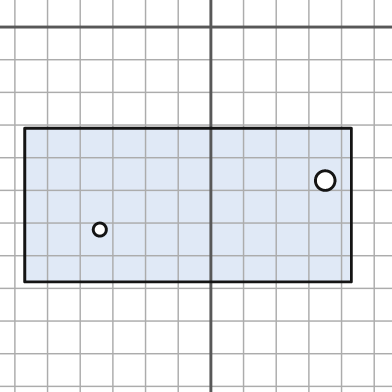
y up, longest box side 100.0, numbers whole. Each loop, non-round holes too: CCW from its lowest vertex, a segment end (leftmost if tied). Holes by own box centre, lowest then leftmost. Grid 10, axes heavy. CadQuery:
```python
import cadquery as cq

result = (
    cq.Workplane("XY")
    .moveTo(-57.0, -78.0)
    .lineTo(43.0, -78.0)
    .lineTo(43.0, -31.0)
    .lineTo(-57.0, -31.0)
    .close()
    .moveTo(-34.0, -62.0)
    .circle(2.0)
    .moveTo(35.0, -47.0)
    .circle(3.0)
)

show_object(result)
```